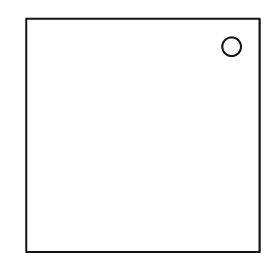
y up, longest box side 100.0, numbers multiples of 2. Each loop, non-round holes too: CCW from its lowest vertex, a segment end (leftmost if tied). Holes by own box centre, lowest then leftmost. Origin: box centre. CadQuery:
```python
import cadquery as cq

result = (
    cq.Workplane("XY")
    .moveTo(-50.0, -50.0)
    .lineTo(50.0, -50.0)
    .lineTo(50.0, 50.0)
    .lineTo(-50.0, 50.0)
    .close()
    .moveTo(38.0, 38.0)
    .circle(4.0)
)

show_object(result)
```